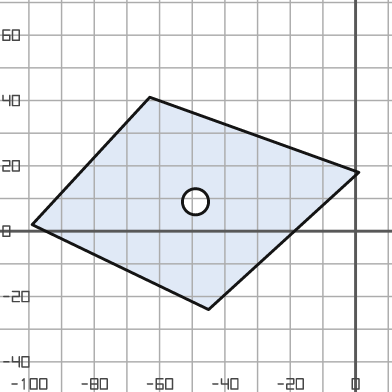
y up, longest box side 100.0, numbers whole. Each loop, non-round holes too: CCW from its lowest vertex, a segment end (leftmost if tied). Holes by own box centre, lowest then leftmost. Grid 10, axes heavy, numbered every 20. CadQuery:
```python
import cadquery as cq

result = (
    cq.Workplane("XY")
    .moveTo(-45.0, -24.0)
    .lineTo(1.0, 18.0)
    .lineTo(-63.0, 41.0)
    .lineTo(-99.0, 2.0)
    .close()
    .moveTo(-49.0, 9.0)
    .circle(4.0)
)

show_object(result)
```